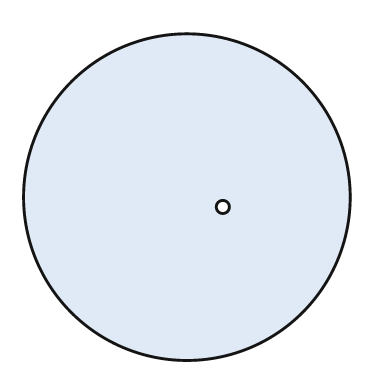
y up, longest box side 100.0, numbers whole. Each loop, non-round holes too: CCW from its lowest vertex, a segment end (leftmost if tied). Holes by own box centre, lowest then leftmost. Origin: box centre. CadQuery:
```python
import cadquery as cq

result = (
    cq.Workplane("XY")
    .moveTo(0.0, 0.0)
    .circle(50.0)
    .moveTo(11.0, -3.0)
    .circle(2.0)
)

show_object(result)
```